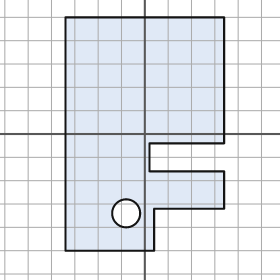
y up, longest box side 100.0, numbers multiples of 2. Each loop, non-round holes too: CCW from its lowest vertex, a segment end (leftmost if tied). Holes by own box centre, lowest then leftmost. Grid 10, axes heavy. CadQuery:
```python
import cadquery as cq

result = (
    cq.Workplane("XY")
    .moveTo(-34.0, -50.0)
    .lineTo(4.0, -50.0)
    .lineTo(4.0, -32.0)
    .lineTo(34.0, -32.0)
    .lineTo(34.0, -16.0)
    .lineTo(2.0, -16.0)
    .lineTo(2.0, -4.0)
    .lineTo(34.0, -4.0)
    .lineTo(34.0, 50.0)
    .lineTo(-34.0, 50.0)
    .close()
    .moveTo(-8.0, -34.0)
    .circle(6.0)
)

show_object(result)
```